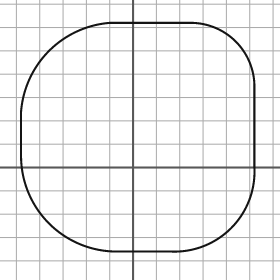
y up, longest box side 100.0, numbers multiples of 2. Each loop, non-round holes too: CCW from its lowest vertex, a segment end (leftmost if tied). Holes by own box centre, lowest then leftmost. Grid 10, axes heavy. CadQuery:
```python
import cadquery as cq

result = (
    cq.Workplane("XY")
    .moveTo(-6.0, -36.0)
    .lineTo(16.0, -36.0)
    .threePointArc((42.0, -26.0), (52.0, 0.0))
    .lineTo(52.0, 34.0)
    .threePointArc((44.0, 54.0), (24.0, 62.0))
    .lineTo(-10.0, 62.0)
    .threePointArc((-36.0, 50.0), (-48.0, 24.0))
    .lineTo(-48.0, 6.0)
    .threePointArc((-36.0, -24.0), (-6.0, -36.0))
    .close()
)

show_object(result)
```